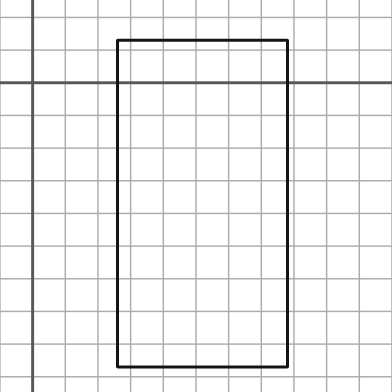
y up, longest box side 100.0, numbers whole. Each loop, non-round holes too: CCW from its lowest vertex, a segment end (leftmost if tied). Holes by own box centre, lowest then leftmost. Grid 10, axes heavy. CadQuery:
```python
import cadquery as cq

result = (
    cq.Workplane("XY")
    .moveTo(26.0, -87.0)
    .lineTo(78.0, -87.0)
    .lineTo(78.0, 13.0)
    .lineTo(26.0, 13.0)
    .close()
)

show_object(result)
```